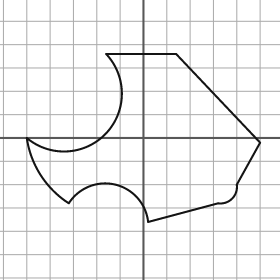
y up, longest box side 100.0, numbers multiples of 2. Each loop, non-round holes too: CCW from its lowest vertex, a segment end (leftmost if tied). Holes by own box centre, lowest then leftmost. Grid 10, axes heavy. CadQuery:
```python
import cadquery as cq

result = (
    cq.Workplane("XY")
    .moveTo(2.0, -36.0)
    .lineTo(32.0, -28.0)
    .threePointArc((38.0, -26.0), (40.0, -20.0))
    .lineTo(50.0, -2.0)
    .lineTo(14.0, 36.0)
    .lineTo(-16.0, 36.0)
    .threePointArc((-16.0, 2.0), (-50.0, 0.0))
    .threePointArc((-44.0, -16.0), (-32.0, -28.0))
    .threePointArc((-12.0, -20.0), (2.0, -36.0))
    .close()
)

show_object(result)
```